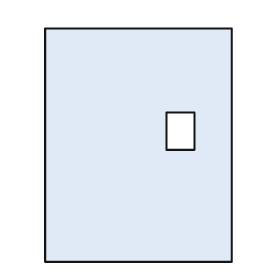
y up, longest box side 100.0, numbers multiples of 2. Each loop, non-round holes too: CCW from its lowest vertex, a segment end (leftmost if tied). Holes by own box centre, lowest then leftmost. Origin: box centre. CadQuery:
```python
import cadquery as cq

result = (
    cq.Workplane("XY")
    .moveTo(-40.0, -50.0)
    .lineTo(40.0, -50.0)
    .lineTo(40.0, 50.0)
    .lineTo(-40.0, 50.0)
    .close()
    .moveTo(12.0, -2.0)
    .lineTo(24.0, -2.0)
    .lineTo(24.0, 14.0)
    .lineTo(12.0, 14.0)
    .close()
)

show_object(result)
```